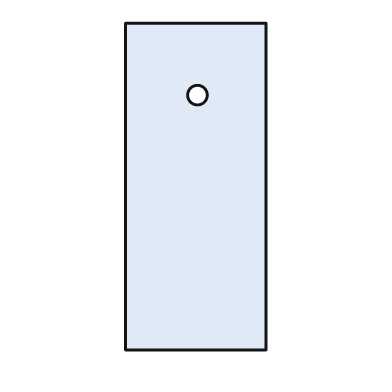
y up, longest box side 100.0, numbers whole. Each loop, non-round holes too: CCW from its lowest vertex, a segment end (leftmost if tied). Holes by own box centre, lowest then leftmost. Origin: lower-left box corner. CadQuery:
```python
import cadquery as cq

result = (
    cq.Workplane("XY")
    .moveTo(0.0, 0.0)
    .lineTo(43.0, 0.0)
    .lineTo(43.0, 100.0)
    .lineTo(0.0, 100.0)
    .close()
    .moveTo(22.0, 78.0)
    .circle(3.0)
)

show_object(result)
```